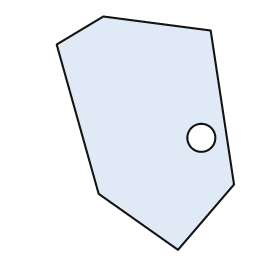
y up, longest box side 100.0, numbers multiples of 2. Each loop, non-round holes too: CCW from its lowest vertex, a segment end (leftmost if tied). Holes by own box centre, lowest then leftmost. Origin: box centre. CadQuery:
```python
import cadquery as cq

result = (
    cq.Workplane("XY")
    .moveTo(14.0, -50.0)
    .lineTo(38.0, -22.0)
    .lineTo(28.0, 44.0)
    .lineTo(-18.0, 50.0)
    .lineTo(-38.0, 38.0)
    .lineTo(-20.0, -26.0)
    .close()
    .moveTo(24.0, -2.0)
    .circle(6.0)
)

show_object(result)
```